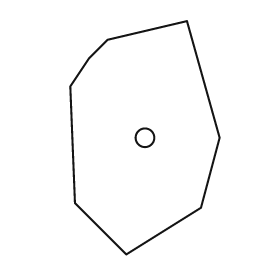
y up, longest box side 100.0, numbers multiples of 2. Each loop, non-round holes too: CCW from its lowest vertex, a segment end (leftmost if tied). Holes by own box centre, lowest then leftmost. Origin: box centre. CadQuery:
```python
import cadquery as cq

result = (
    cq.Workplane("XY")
    .moveTo(-8.0, -50.0)
    .lineTo(24.0, -30.0)
    .lineTo(32.0, 0.0)
    .lineTo(18.0, 50.0)
    .lineTo(-16.0, 42.0)
    .lineTo(-24.0, 34.0)
    .lineTo(-32.0, 22.0)
    .lineTo(-30.0, -28.0)
    .close()
    .moveTo(0.0, 0.0)
    .circle(4.0)
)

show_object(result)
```